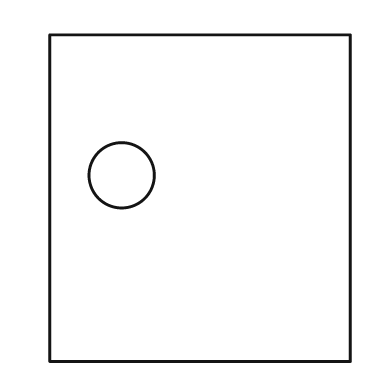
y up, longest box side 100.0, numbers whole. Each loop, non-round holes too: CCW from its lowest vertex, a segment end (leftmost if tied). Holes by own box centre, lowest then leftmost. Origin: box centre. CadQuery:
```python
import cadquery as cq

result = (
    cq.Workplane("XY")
    .moveTo(-46.0, -50.0)
    .lineTo(46.0, -50.0)
    .lineTo(46.0, 50.0)
    .lineTo(-46.0, 50.0)
    .close()
    .moveTo(-24.0, 7.0)
    .circle(10.0)
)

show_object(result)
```